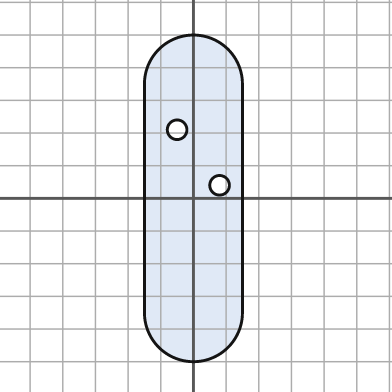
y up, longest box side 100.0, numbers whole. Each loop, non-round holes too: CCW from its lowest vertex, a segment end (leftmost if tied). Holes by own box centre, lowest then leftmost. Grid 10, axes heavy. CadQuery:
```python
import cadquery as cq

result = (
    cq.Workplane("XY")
    .moveTo(-15.0, -35.0)
    .threePointArc((0.0, -50.0), (15.0, -35.0))
    .lineTo(15.0, 35.0)
    .threePointArc((0.0, 50.0), (-15.0, 35.0))
    .close()
    .moveTo(8.0, 4.0)
    .circle(3.0)
    .moveTo(-5.0, 21.0)
    .circle(3.0)
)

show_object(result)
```